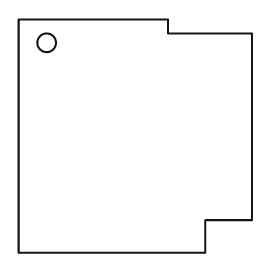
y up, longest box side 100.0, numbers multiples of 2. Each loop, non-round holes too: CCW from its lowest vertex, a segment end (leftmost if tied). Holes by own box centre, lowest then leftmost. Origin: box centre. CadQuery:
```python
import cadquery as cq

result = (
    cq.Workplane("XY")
    .moveTo(-50.0, -50.0)
    .lineTo(30.0, -50.0)
    .lineTo(30.0, -36.0)
    .lineTo(50.0, -36.0)
    .lineTo(50.0, 44.0)
    .lineTo(14.0, 44.0)
    .lineTo(14.0, 50.0)
    .lineTo(-50.0, 50.0)
    .close()
    .moveTo(-38.0, 40.0)
    .circle(4.0)
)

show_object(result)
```